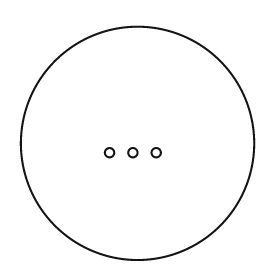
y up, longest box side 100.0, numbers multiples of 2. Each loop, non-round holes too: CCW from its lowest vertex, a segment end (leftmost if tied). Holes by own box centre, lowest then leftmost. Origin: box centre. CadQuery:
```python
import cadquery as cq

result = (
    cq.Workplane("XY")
    .moveTo(0.0, 0.0)
    .circle(50.0)
    .moveTo(-12.0, -4.0)
    .circle(2.0)
    .moveTo(-2.0, -4.0)
    .circle(2.0)
    .moveTo(8.0, -4.0)
    .circle(2.0)
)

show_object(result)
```